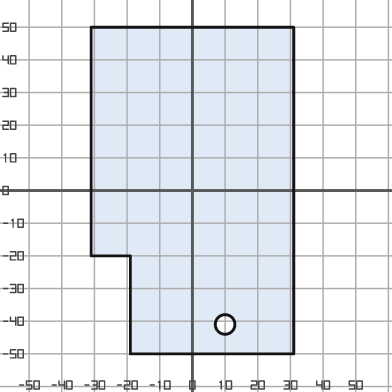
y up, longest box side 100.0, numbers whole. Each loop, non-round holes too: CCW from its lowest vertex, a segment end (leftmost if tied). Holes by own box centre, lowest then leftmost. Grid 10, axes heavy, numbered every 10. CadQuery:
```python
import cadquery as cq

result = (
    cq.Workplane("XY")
    .moveTo(-19.0, -50.0)
    .lineTo(31.0, -50.0)
    .lineTo(31.0, 50.0)
    .lineTo(-31.0, 50.0)
    .lineTo(-31.0, -20.0)
    .lineTo(-19.0, -20.0)
    .close()
    .moveTo(10.0, -41.0)
    .circle(3.0)
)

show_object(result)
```